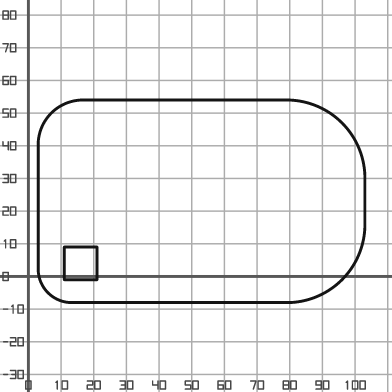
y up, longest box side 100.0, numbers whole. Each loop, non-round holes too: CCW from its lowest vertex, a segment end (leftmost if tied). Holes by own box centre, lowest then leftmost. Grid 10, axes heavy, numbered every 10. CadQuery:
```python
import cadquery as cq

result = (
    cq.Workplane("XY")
    .moveTo(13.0, -8.0)
    .lineTo(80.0, -8.0)
    .threePointArc((96.0, -1.0), (103.0, 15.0))
    .lineTo(103.0, 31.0)
    .threePointArc((96.0, 47.0), (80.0, 54.0))
    .lineTo(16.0, 54.0)
    .threePointArc((7.0, 50.0), (3.0, 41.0))
    .lineTo(3.0, 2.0)
    .threePointArc((6.0, -5.0), (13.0, -8.0))
    .close()
    .moveTo(11.0, -1.0)
    .lineTo(21.0, -1.0)
    .lineTo(21.0, 9.0)
    .lineTo(11.0, 9.0)
    .close()
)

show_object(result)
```